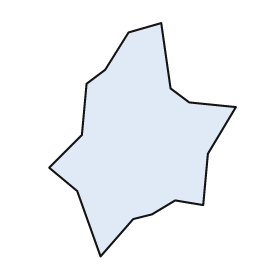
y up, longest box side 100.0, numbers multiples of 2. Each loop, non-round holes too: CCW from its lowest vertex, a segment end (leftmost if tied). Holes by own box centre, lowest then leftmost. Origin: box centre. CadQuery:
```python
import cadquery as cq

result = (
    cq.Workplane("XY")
    .moveTo(-18.0, -50.0)
    .lineTo(-4.0, -34.0)
    .lineTo(4.0, -32.0)
    .lineTo(14.0, -26.0)
    .lineTo(26.0, -28.0)
    .lineTo(28.0, -6.0)
    .lineTo(40.0, 14.0)
    .lineTo(20.0, 16.0)
    .lineTo(12.0, 22.0)
    .lineTo(8.0, 50.0)
    .lineTo(-6.0, 46.0)
    .lineTo(-16.0, 30.0)
    .lineTo(-24.0, 24.0)
    .lineTo(-26.0, 2.0)
    .lineTo(-40.0, -12.0)
    .lineTo(-28.0, -22.0)
    .close()
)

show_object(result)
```